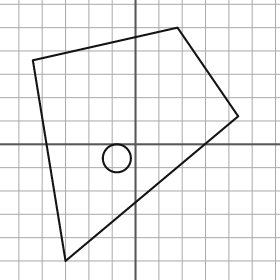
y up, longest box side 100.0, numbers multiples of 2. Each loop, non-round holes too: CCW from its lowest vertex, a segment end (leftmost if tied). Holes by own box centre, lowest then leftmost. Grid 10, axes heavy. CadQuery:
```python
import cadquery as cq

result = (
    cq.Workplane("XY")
    .moveTo(-30.0, -50.0)
    .lineTo(44.0, 12.0)
    .lineTo(18.0, 50.0)
    .lineTo(-44.0, 36.0)
    .close()
    .moveTo(-8.0, -6.0)
    .circle(6.0)
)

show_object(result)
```